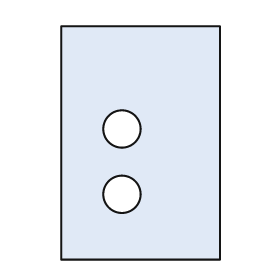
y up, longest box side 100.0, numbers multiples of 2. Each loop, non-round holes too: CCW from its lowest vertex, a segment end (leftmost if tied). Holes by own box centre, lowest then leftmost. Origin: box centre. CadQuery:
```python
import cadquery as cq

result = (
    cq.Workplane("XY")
    .moveTo(-34.0, -50.0)
    .lineTo(34.0, -50.0)
    .lineTo(34.0, 50.0)
    .lineTo(-34.0, 50.0)
    .close()
    .moveTo(-8.0, -22.0)
    .circle(8.0)
    .moveTo(-8.0, 6.0)
    .circle(8.0)
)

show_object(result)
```